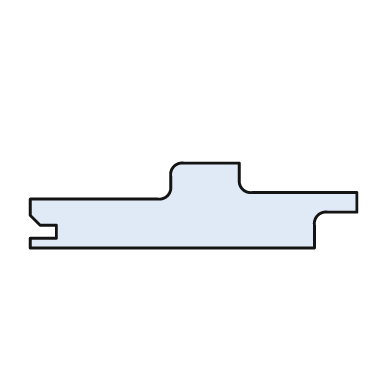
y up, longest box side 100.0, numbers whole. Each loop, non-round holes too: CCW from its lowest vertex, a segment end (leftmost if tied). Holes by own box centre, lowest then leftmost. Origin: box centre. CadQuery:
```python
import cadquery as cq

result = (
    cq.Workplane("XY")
    .moveTo(-50.0, -13.0)
    .lineTo(37.0, -13.0)
    .lineTo(37.0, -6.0)
    .threePointArc((38.0, -3.0), (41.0, -2.0))
    .lineTo(50.0, -2.0)
    .lineTo(50.0, 4.0)
    .lineTo(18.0, 4.0)
    .threePointArc((15.0, 5.0), (14.0, 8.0))
    .lineTo(14.0, 13.0)
    .lineTo(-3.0, 13.0)
    .threePointArc((-6.0, 12.0), (-7.0, 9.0))
    .lineTo(-7.0, 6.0)
    .threePointArc((-8.0, 3.0), (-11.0, 2.0))
    .lineTo(-50.0, 2.0)
    .lineTo(-50.0, -3.0)
    .lineTo(-47.0, -6.0)
    .lineTo(-42.0, -6.0)
    .lineTo(-42.0, -10.0)
    .lineTo(-50.0, -10.0)
    .close()
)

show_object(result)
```